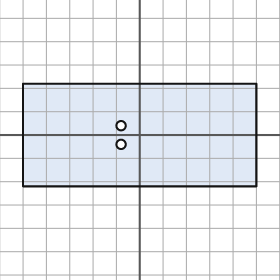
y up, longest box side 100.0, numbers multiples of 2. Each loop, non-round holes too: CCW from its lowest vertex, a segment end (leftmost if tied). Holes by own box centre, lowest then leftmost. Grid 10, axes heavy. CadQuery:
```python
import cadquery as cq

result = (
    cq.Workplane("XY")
    .moveTo(-50.0, -22.0)
    .lineTo(50.0, -22.0)
    .lineTo(50.0, 22.0)
    .lineTo(-50.0, 22.0)
    .close()
    .moveTo(-8.0, -4.0)
    .circle(2.0)
    .moveTo(-8.0, 4.0)
    .circle(2.0)
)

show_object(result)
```